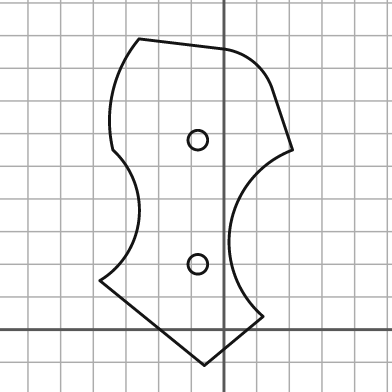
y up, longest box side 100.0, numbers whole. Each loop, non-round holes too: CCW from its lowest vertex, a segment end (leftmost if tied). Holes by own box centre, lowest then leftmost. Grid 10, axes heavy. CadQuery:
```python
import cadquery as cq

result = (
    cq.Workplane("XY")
    .moveTo(-6.0, -11.0)
    .lineTo(12.0, 4.0)
    .threePointArc((2.0, 32.0), (21.0, 55.0))
    .lineTo(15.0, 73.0)
    .threePointArc((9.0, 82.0), (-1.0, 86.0))
    .lineTo(-26.0, 89.0)
    .threePointArc((-34.0, 73.0), (-34.0, 55.0))
    .threePointArc((-26.0, 34.0), (-38.0, 15.0))
    .close()
    .moveTo(-8.0, 20.0)
    .circle(3.0)
    .moveTo(-8.0, 58.0)
    .circle(3.0)
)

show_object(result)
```